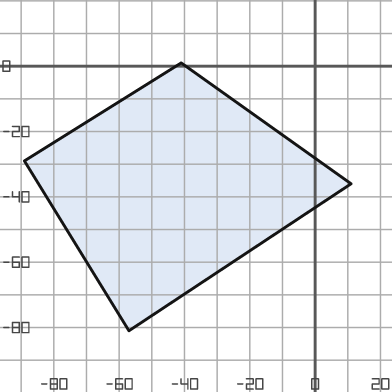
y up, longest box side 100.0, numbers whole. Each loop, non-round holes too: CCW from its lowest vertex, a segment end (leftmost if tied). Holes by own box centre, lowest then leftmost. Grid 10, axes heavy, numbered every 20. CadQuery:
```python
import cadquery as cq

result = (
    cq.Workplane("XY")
    .moveTo(-57.0, -81.0)
    .lineTo(11.0, -36.0)
    .lineTo(-41.0, 1.0)
    .lineTo(-89.0, -29.0)
    .close()
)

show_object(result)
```